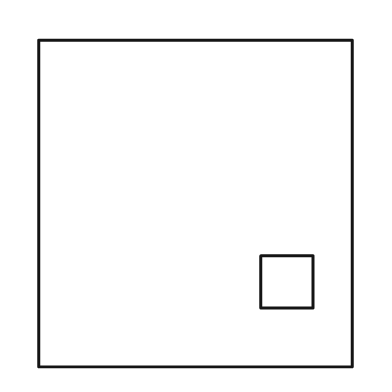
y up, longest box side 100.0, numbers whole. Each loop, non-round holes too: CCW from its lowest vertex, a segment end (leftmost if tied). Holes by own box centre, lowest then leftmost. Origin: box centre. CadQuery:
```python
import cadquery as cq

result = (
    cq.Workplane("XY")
    .moveTo(-48.0, -50.0)
    .lineTo(48.0, -50.0)
    .lineTo(48.0, 50.0)
    .lineTo(-48.0, 50.0)
    .close()
    .moveTo(20.0, -32.0)
    .lineTo(36.0, -32.0)
    .lineTo(36.0, -16.0)
    .lineTo(20.0, -16.0)
    .close()
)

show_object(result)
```